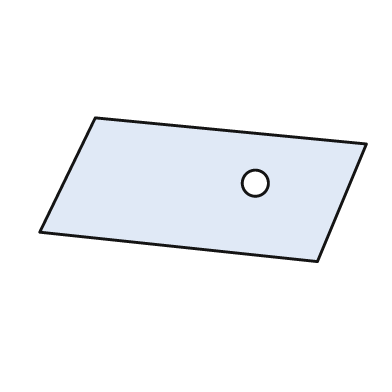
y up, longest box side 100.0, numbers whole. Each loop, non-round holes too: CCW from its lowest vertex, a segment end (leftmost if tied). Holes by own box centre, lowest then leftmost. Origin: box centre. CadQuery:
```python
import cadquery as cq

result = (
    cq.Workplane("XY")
    .moveTo(35.0, -22.0)
    .lineTo(50.0, 14.0)
    .lineTo(-33.0, 22.0)
    .lineTo(-50.0, -13.0)
    .close()
    .moveTo(16.0, 2.0)
    .circle(4.0)
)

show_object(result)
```